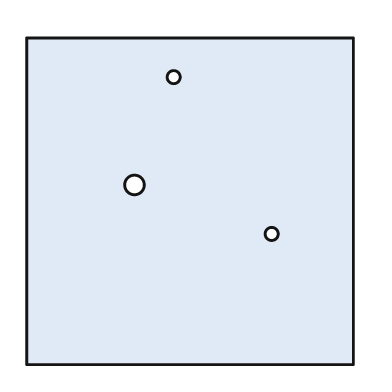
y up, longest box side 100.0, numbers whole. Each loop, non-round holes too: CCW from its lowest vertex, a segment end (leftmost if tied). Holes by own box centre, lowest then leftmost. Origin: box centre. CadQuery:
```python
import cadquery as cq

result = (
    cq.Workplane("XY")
    .moveTo(-50.0, -50.0)
    .lineTo(50.0, -50.0)
    .lineTo(50.0, 50.0)
    .lineTo(-50.0, 50.0)
    .close()
    .moveTo(25.0, -10.0)
    .circle(2.0)
    .moveTo(-17.0, 5.0)
    .circle(3.0)
    .moveTo(-5.0, 38.0)
    .circle(2.0)
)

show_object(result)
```